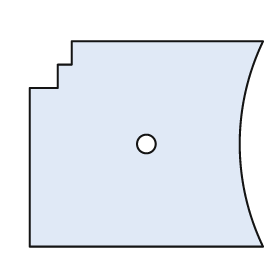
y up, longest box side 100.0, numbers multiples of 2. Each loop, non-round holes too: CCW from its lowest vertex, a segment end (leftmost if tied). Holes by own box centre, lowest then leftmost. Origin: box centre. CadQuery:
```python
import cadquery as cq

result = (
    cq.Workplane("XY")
    .moveTo(-50.0, -44.0)
    .lineTo(50.0, -44.0)
    .threePointArc((40.0, 0.0), (50.0, 44.0))
    .lineTo(-32.0, 44.0)
    .lineTo(-32.0, 34.0)
    .lineTo(-38.0, 34.0)
    .lineTo(-38.0, 24.0)
    .lineTo(-50.0, 24.0)
    .close()
    .moveTo(0.0, 0.0)
    .circle(4.0)
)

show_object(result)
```